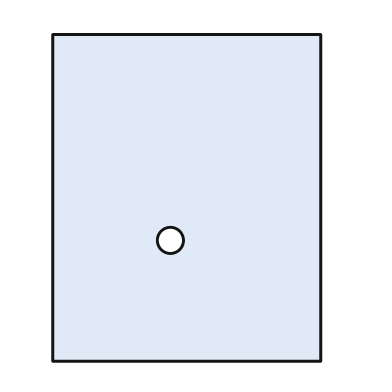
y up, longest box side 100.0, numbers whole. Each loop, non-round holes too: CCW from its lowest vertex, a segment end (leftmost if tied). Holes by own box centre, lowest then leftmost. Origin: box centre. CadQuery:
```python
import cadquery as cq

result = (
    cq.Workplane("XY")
    .moveTo(-41.0, -50.0)
    .lineTo(41.0, -50.0)
    .lineTo(41.0, 50.0)
    .lineTo(-41.0, 50.0)
    .close()
    .moveTo(-5.0, -13.0)
    .circle(4.0)
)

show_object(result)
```